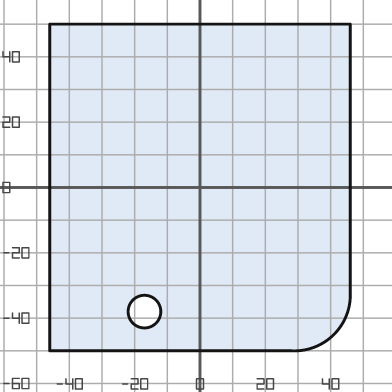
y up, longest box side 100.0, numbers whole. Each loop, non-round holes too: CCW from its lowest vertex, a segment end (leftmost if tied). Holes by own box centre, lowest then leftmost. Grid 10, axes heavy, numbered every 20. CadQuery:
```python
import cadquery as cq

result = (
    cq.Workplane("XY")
    .moveTo(-46.0, -50.0)
    .lineTo(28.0, -50.0)
    .threePointArc((41.0, -45.0), (46.0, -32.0))
    .lineTo(46.0, 50.0)
    .lineTo(-46.0, 50.0)
    .close()
    .moveTo(-17.0, -38.0)
    .circle(5.0)
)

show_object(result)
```